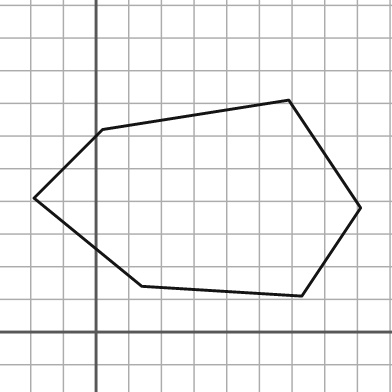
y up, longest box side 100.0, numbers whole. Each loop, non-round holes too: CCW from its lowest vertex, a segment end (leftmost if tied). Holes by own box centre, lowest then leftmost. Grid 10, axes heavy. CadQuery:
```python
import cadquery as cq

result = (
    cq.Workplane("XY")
    .moveTo(63.0, 11.0)
    .lineTo(81.0, 38.0)
    .lineTo(59.0, 71.0)
    .lineTo(2.0, 62.0)
    .lineTo(-19.0, 41.0)
    .lineTo(14.0, 14.0)
    .close()
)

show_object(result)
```